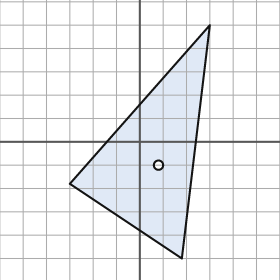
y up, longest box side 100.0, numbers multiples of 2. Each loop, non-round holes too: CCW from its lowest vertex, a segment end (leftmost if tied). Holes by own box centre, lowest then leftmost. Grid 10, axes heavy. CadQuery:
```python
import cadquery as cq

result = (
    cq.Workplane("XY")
    .moveTo(18.0, -50.0)
    .lineTo(30.0, 50.0)
    .lineTo(-30.0, -18.0)
    .close()
    .moveTo(8.0, -10.0)
    .circle(2.0)
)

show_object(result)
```